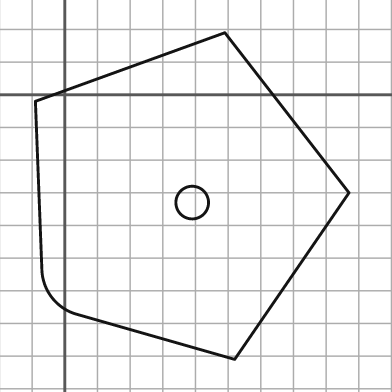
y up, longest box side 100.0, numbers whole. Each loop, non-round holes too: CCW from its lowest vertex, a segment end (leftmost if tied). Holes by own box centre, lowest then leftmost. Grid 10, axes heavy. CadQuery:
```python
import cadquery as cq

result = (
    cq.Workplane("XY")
    .moveTo(52.0, -81.0)
    .lineTo(87.0, -30.0)
    .lineTo(49.0, 19.0)
    .lineTo(-9.0, -2.0)
    .lineTo(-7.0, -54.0)
    .threePointArc((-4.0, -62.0), (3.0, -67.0))
    .close()
    .moveTo(39.0, -33.0)
    .circle(5.0)
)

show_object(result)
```